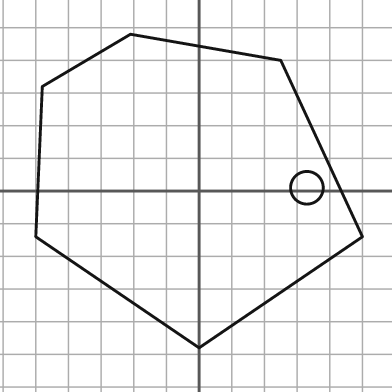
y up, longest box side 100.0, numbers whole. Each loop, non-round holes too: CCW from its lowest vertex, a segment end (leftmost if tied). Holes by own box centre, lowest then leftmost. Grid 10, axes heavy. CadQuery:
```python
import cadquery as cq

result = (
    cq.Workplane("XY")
    .moveTo(0.0, -48.0)
    .lineTo(50.0, -14.0)
    .lineTo(25.0, 40.0)
    .lineTo(-21.0, 48.0)
    .lineTo(-48.0, 32.0)
    .lineTo(-50.0, -14.0)
    .close()
    .moveTo(33.0, 1.0)
    .circle(5.0)
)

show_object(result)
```